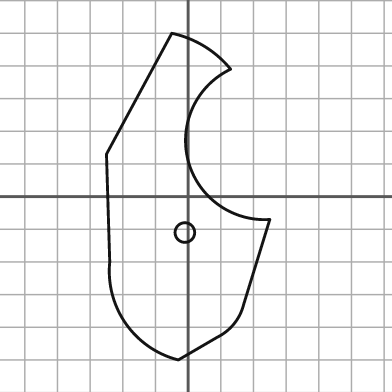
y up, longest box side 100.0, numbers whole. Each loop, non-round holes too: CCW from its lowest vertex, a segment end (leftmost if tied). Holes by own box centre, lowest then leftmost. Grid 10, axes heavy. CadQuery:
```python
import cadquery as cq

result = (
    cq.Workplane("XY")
    .moveTo(-3.0, -50.0)
    .lineTo(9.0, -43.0)
    .threePointArc((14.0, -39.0), (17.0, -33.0))
    .lineTo(25.0, -7.0)
    .threePointArc((0.0, 11.0), (13.0, 39.0))
    .threePointArc((5.0, 46.0), (-5.0, 50.0))
    .lineTo(-25.0, 13.0)
    .lineTo(-24.0, -20.0)
    .threePointArc((-19.0, -39.0), (-3.0, -50.0))
    .close()
    .moveTo(-1.0, -11.0)
    .circle(3.0)
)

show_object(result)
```